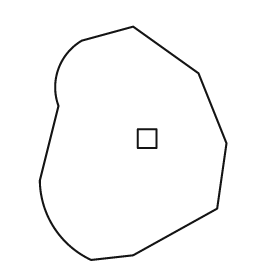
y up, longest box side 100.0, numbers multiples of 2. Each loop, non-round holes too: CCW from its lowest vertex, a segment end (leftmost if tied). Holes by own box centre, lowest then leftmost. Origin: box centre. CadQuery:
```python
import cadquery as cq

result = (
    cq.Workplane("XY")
    .moveTo(-18.0, -50.0)
    .lineTo(0.0, -48.0)
    .lineTo(36.0, -28.0)
    .lineTo(40.0, 0.0)
    .lineTo(28.0, 30.0)
    .lineTo(0.0, 50.0)
    .lineTo(-22.0, 44.0)
    .threePointArc((-32.0, 32.0), (-32.0, 16.0))
    .lineTo(-40.0, -16.0)
    .threePointArc((-34.0, -36.0), (-18.0, -50.0))
    .close()
    .moveTo(2.0, -2.0)
    .lineTo(10.0, -2.0)
    .lineTo(10.0, 6.0)
    .lineTo(2.0, 6.0)
    .close()
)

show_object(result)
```